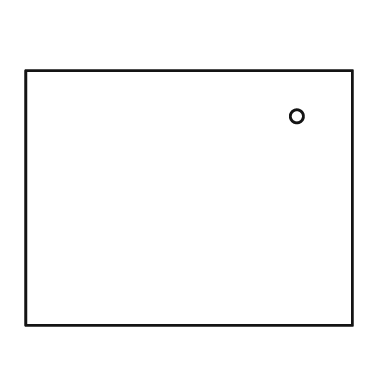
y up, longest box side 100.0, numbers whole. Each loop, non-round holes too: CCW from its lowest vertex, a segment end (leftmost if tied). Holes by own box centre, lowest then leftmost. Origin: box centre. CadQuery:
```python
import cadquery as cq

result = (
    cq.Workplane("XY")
    .moveTo(-50.0, -39.0)
    .lineTo(50.0, -39.0)
    .lineTo(50.0, 39.0)
    .lineTo(-50.0, 39.0)
    .close()
    .moveTo(33.0, 25.0)
    .circle(2.0)
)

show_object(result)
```